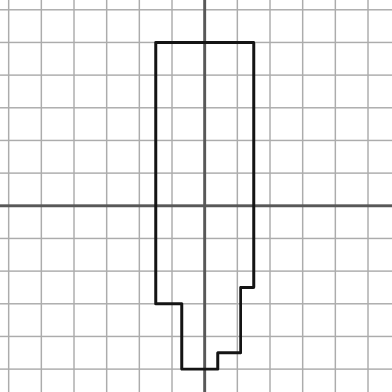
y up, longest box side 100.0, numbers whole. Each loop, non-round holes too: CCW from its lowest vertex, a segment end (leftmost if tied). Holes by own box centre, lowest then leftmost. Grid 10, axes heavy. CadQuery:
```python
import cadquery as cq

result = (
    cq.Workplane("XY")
    .moveTo(-7.0, -50.0)
    .lineTo(4.0, -50.0)
    .lineTo(4.0, -45.0)
    .lineTo(11.0, -45.0)
    .lineTo(11.0, -25.0)
    .lineTo(15.0, -25.0)
    .lineTo(15.0, 50.0)
    .lineTo(-15.0, 50.0)
    .lineTo(-15.0, -30.0)
    .lineTo(-7.0, -30.0)
    .close()
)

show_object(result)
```